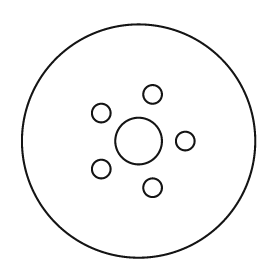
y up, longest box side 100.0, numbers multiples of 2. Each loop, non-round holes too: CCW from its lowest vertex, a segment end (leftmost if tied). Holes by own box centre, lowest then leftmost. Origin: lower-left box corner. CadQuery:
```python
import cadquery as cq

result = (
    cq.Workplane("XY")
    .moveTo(50.0, 50.0)
    .circle(50.0)
    .moveTo(56.0, 30.0)
    .circle(4.0)
    .moveTo(34.0, 38.0)
    .circle(4.0)
    .moveTo(50.0, 50.0)
    .circle(10.0)
    .moveTo(70.0, 50.0)
    .circle(4.0)
    .moveTo(34.0, 62.0)
    .circle(4.0)
    .moveTo(56.0, 70.0)
    .circle(4.0)
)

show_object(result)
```